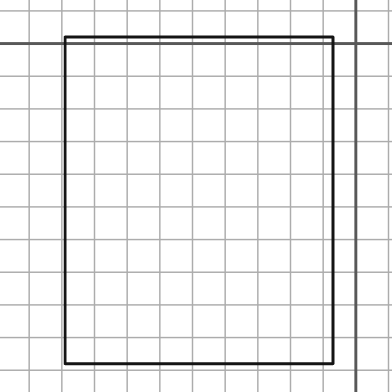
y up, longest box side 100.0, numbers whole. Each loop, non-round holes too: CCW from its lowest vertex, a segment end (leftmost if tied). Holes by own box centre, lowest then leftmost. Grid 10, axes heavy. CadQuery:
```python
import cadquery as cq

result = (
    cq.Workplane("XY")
    .moveTo(-89.0, -98.0)
    .lineTo(-7.0, -98.0)
    .lineTo(-7.0, 2.0)
    .lineTo(-89.0, 2.0)
    .close()
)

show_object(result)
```